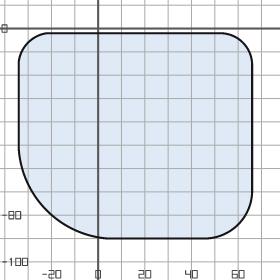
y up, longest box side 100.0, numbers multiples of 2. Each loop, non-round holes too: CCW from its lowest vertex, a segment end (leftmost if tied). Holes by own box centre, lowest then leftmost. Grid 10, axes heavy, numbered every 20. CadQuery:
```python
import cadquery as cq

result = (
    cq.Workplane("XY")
    .moveTo(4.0, -90.0)
    .lineTo(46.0, -90.0)
    .threePointArc((60.0, -84.0), (66.0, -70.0))
    .lineTo(66.0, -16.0)
    .threePointArc((62.0, -6.0), (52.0, -2.0))
    .lineTo(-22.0, -2.0)
    .threePointArc((-30.0, -6.0), (-34.0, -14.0))
    .lineTo(-34.0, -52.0)
    .threePointArc((-22.0, -78.0), (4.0, -90.0))
    .close()
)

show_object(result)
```